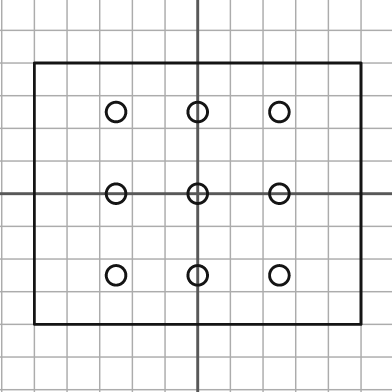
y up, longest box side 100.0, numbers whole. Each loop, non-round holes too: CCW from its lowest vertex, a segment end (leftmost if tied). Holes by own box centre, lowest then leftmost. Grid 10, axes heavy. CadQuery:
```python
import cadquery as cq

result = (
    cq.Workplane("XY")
    .moveTo(-50.0, -40.0)
    .lineTo(50.0, -40.0)
    .lineTo(50.0, 40.0)
    .lineTo(-50.0, 40.0)
    .close()
    .moveTo(-25.0, -25.0)
    .circle(3.0)
    .moveTo(0.0, -25.0)
    .circle(3.0)
    .moveTo(25.0, -25.0)
    .circle(3.0)
    .moveTo(-25.0, 0.0)
    .circle(3.0)
    .moveTo(0.0, 0.0)
    .circle(3.0)
    .moveTo(25.0, 0.0)
    .circle(3.0)
    .moveTo(-25.0, 25.0)
    .circle(3.0)
    .moveTo(0.0, 25.0)
    .circle(3.0)
    .moveTo(25.0, 25.0)
    .circle(3.0)
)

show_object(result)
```